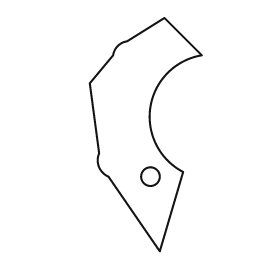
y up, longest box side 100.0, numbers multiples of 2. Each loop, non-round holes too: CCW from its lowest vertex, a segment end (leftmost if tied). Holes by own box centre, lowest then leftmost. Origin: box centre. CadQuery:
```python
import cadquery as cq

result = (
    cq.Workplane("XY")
    .moveTo(6.0, -50.0)
    .lineTo(16.0, -16.0)
    .threePointArc((2.0, 12.0), (24.0, 34.0))
    .lineTo(8.0, 50.0)
    .lineTo(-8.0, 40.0)
    .threePointArc((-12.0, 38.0), (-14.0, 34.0))
    .lineTo(-24.0, 22.0)
    .lineTo(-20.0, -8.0)
    .threePointArc((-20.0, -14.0), (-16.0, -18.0))
    .close()
    .moveTo(2.0, -18.0)
    .circle(4.0)
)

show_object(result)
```